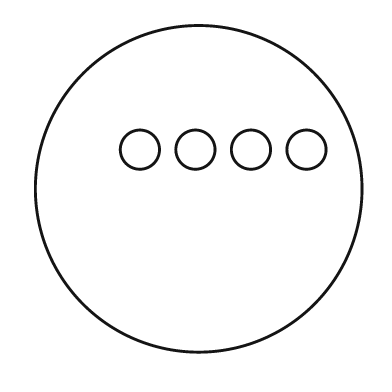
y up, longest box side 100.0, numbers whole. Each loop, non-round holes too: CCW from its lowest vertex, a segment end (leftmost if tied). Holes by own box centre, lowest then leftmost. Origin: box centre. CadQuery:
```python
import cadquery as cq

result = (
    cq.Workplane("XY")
    .moveTo(0.0, 0.0)
    .circle(50.0)
    .moveTo(-18.0, 12.0)
    .circle(6.0)
    .moveTo(-1.0, 12.0)
    .circle(6.0)
    .moveTo(16.0, 12.0)
    .circle(6.0)
    .moveTo(33.0, 12.0)
    .circle(6.0)
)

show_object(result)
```